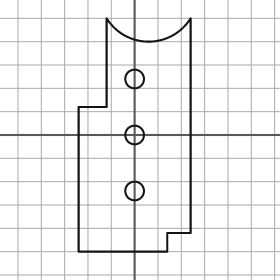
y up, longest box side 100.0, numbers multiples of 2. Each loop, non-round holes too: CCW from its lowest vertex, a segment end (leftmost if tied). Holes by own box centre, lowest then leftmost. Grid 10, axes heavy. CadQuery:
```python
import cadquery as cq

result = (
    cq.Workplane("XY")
    .moveTo(-24.0, -50.0)
    .lineTo(14.0, -50.0)
    .lineTo(14.0, -42.0)
    .lineTo(24.0, -42.0)
    .lineTo(24.0, 50.0)
    .threePointArc((6.0, 40.0), (-12.0, 50.0))
    .lineTo(-12.0, 12.0)
    .lineTo(-24.0, 12.0)
    .close()
    .moveTo(0.0, -24.0)
    .circle(4.0)
    .moveTo(0.0, 0.0)
    .circle(4.0)
    .moveTo(0.0, 24.0)
    .circle(4.0)
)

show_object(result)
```